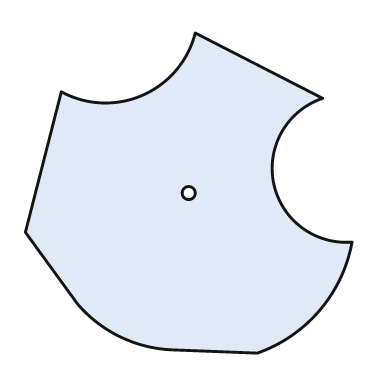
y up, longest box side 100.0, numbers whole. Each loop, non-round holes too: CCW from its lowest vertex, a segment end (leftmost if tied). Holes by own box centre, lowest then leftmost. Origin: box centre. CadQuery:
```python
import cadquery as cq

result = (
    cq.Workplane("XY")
    .moveTo(21.0, -49.0)
    .threePointArc((40.0, -36.0), (50.0, -15.0))
    .threePointArc((26.0, 3.0), (41.0, 29.0))
    .lineTo(2.0, 49.0)
    .threePointArc((-14.0, 30.0), (-39.0, 31.0))
    .lineTo(-50.0, -12.0)
    .lineTo(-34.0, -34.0)
    .threePointArc((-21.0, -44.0), (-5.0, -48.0))
    .close()
    .moveTo(0.0, 0.0)
    .circle(2.0)
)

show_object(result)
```